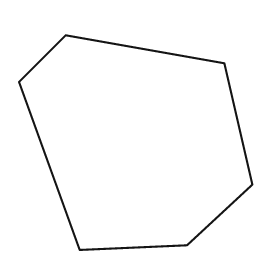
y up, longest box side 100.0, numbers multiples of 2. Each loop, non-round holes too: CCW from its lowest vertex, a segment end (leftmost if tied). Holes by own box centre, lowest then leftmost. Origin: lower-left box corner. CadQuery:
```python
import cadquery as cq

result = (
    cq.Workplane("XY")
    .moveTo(26.0, 0.0)
    .lineTo(72.0, 2.0)
    .lineTo(100.0, 28.0)
    .lineTo(88.0, 80.0)
    .lineTo(20.0, 92.0)
    .lineTo(0.0, 72.0)
    .close()
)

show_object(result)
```